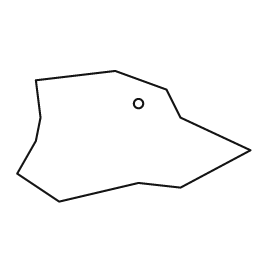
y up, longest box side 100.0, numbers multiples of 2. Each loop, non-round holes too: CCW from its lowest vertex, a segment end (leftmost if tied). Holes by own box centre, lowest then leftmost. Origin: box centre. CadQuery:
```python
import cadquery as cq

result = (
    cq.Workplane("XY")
    .moveTo(-32.0, -28.0)
    .lineTo(2.0, -20.0)
    .lineTo(20.0, -22.0)
    .lineTo(50.0, -6.0)
    .lineTo(20.0, 8.0)
    .lineTo(14.0, 20.0)
    .lineTo(-8.0, 28.0)
    .lineTo(-42.0, 24.0)
    .lineTo(-40.0, 8.0)
    .lineTo(-42.0, -2.0)
    .lineTo(-50.0, -16.0)
    .close()
    .moveTo(2.0, 14.0)
    .circle(2.0)
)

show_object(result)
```